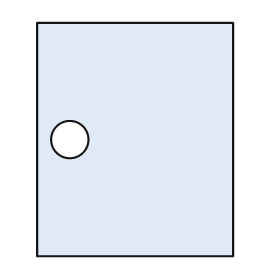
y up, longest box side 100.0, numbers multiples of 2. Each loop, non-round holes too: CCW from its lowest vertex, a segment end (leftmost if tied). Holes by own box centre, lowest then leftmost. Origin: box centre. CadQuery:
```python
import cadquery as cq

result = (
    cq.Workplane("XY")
    .moveTo(-42.0, -50.0)
    .lineTo(42.0, -50.0)
    .lineTo(42.0, 50.0)
    .lineTo(-42.0, 50.0)
    .close()
    .moveTo(-28.0, 0.0)
    .circle(8.0)
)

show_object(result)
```